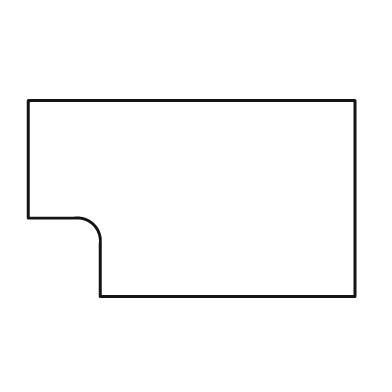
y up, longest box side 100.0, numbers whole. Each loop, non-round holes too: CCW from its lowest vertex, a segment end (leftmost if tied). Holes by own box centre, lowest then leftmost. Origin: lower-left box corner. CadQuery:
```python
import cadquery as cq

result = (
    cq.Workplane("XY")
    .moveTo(22.0, 0.0)
    .lineTo(100.0, 0.0)
    .lineTo(100.0, 60.0)
    .lineTo(0.0, 60.0)
    .lineTo(0.0, 24.0)
    .lineTo(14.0, 24.0)
    .threePointArc((20.0, 22.0), (22.0, 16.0))
    .close()
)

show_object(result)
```